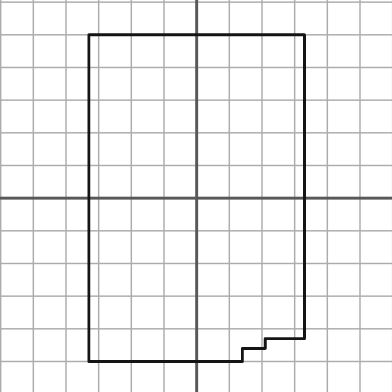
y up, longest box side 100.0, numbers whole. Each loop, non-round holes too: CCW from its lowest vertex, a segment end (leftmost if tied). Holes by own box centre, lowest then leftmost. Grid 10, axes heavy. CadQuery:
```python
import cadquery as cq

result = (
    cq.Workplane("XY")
    .moveTo(-33.0, -50.0)
    .lineTo(14.0, -50.0)
    .lineTo(14.0, -46.0)
    .lineTo(21.0, -46.0)
    .lineTo(21.0, -43.0)
    .lineTo(33.0, -43.0)
    .lineTo(33.0, 50.0)
    .lineTo(-33.0, 50.0)
    .close()
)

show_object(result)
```